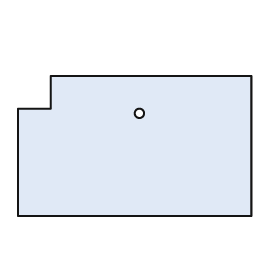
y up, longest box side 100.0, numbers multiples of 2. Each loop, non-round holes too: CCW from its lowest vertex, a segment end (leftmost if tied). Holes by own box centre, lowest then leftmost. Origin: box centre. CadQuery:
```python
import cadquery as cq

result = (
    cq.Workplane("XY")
    .moveTo(-50.0, -30.0)
    .lineTo(50.0, -30.0)
    .lineTo(50.0, 30.0)
    .lineTo(-36.0, 30.0)
    .lineTo(-36.0, 16.0)
    .lineTo(-50.0, 16.0)
    .close()
    .moveTo(2.0, 14.0)
    .circle(2.0)
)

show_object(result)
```